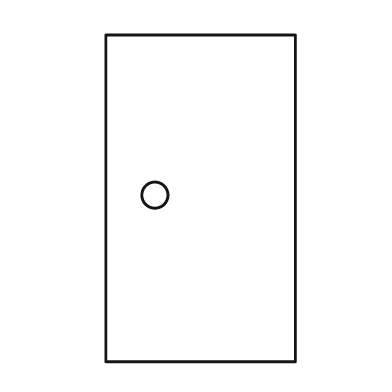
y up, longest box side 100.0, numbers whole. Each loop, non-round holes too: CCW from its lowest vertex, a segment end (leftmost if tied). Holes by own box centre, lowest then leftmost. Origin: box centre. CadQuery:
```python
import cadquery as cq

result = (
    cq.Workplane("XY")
    .moveTo(-29.0, -50.0)
    .lineTo(29.0, -50.0)
    .lineTo(29.0, 50.0)
    .lineTo(-29.0, 50.0)
    .close()
    .moveTo(-14.0, 1.0)
    .circle(4.0)
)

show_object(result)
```